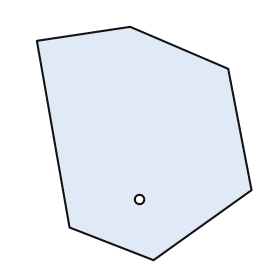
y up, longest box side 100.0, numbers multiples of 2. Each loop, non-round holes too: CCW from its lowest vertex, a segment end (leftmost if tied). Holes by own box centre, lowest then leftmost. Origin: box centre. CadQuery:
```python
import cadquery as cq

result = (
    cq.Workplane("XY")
    .moveTo(4.0, -50.0)
    .lineTo(46.0, -20.0)
    .lineTo(36.0, 32.0)
    .lineTo(-6.0, 50.0)
    .lineTo(-46.0, 44.0)
    .lineTo(-32.0, -36.0)
    .close()
    .moveTo(-2.0, -24.0)
    .circle(2.0)
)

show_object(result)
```